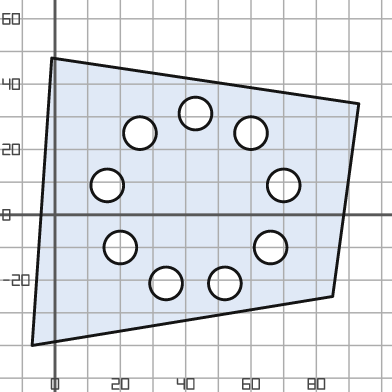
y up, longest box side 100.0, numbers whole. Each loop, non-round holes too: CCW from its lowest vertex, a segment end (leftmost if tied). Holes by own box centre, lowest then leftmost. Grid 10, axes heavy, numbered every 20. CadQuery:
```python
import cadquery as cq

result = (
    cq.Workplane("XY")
    .moveTo(-7.0, -40.0)
    .lineTo(85.0, -25.0)
    .lineTo(93.0, 34.0)
    .lineTo(-1.0, 48.0)
    .close()
    .moveTo(34.0, -21.0)
    .circle(5.0)
    .moveTo(52.0, -21.0)
    .circle(5.0)
    .moveTo(20.0, -10.0)
    .circle(5.0)
    .moveTo(66.0, -10.0)
    .circle(5.0)
    .moveTo(16.0, 9.0)
    .circle(5.0)
    .moveTo(70.0, 9.0)
    .circle(5.0)
    .moveTo(26.0, 25.0)
    .circle(5.0)
    .moveTo(60.0, 25.0)
    .circle(5.0)
    .moveTo(43.0, 31.0)
    .circle(5.0)
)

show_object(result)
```